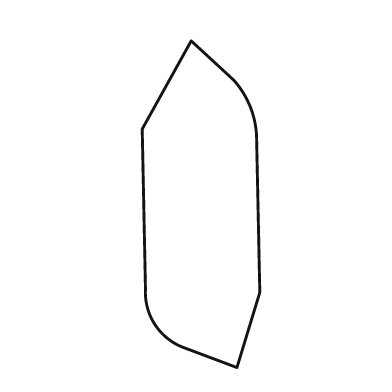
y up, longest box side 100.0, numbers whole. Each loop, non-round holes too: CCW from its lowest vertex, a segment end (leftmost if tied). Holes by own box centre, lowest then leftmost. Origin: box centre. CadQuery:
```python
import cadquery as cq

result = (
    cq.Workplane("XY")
    .moveTo(11.0, -50.0)
    .lineTo(18.0, -27.0)
    .lineTo(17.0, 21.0)
    .threePointArc((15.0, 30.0), (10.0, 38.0))
    .lineTo(-3.0, 50.0)
    .lineTo(-18.0, 23.0)
    .lineTo(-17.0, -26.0)
    .threePointArc((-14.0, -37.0), (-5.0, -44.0))
    .close()
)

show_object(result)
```